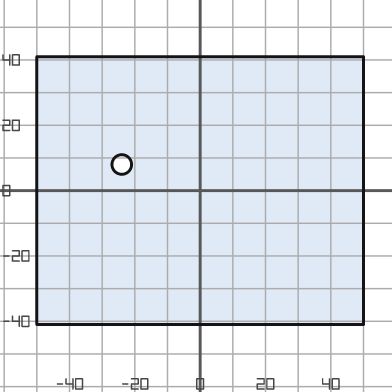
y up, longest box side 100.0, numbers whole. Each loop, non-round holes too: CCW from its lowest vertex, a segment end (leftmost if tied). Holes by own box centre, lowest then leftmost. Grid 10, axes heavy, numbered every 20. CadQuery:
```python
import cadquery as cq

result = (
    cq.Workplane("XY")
    .moveTo(-50.0, -41.0)
    .lineTo(50.0, -41.0)
    .lineTo(50.0, 41.0)
    .lineTo(-50.0, 41.0)
    .close()
    .moveTo(-24.0, 8.0)
    .circle(3.0)
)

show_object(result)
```